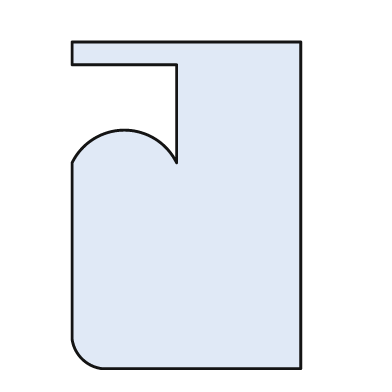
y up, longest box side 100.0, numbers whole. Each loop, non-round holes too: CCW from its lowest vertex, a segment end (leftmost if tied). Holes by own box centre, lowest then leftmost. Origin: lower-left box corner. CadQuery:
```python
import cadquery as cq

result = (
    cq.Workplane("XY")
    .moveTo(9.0, 0.0)
    .lineTo(70.0, 0.0)
    .lineTo(70.0, 100.0)
    .lineTo(0.0, 100.0)
    .lineTo(0.0, 93.0)
    .lineTo(32.0, 93.0)
    .lineTo(32.0, 63.0)
    .threePointArc((16.0, 73.0), (0.0, 63.0))
    .lineTo(0.0, 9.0)
    .threePointArc((3.0, 3.0), (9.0, 0.0))
    .close()
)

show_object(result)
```